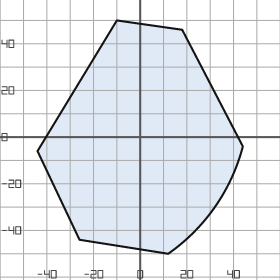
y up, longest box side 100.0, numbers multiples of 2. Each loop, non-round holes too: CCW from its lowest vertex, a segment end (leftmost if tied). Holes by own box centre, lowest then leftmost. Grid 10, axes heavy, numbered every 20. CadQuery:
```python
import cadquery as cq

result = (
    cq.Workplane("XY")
    .moveTo(12.0, -50.0)
    .threePointArc((32.0, -30.0), (44.0, -4.0))
    .lineTo(18.0, 46.0)
    .lineTo(-10.0, 50.0)
    .lineTo(-44.0, -6.0)
    .lineTo(-26.0, -44.0)
    .close()
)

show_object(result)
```